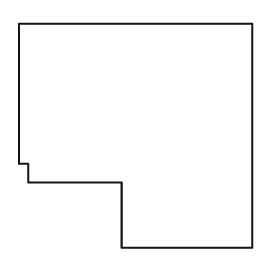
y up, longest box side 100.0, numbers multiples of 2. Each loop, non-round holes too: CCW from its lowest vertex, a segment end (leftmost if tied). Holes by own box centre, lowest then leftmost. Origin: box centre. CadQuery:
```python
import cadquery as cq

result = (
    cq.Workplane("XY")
    .moveTo(-6.0, -48.0)
    .lineTo(50.0, -48.0)
    .lineTo(50.0, 48.0)
    .lineTo(-50.0, 48.0)
    .lineTo(-50.0, -12.0)
    .lineTo(-46.0, -12.0)
    .lineTo(-46.0, -20.0)
    .lineTo(-6.0, -20.0)
    .close()
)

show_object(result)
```